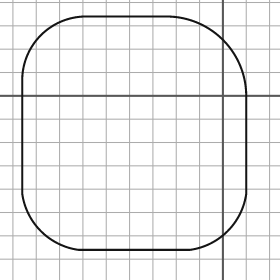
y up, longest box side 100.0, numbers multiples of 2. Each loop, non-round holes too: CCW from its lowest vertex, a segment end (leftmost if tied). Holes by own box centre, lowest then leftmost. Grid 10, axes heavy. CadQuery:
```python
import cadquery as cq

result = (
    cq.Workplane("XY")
    .moveTo(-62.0, -66.0)
    .lineTo(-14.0, -66.0)
    .threePointArc((2.0, -58.0), (10.0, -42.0))
    .lineTo(10.0, 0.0)
    .threePointArc((0.0, 24.0), (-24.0, 34.0))
    .lineTo(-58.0, 34.0)
    .threePointArc((-78.0, 26.0), (-86.0, 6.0))
    .lineTo(-86.0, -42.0)
    .threePointArc((-78.0, -58.0), (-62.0, -66.0))
    .close()
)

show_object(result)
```